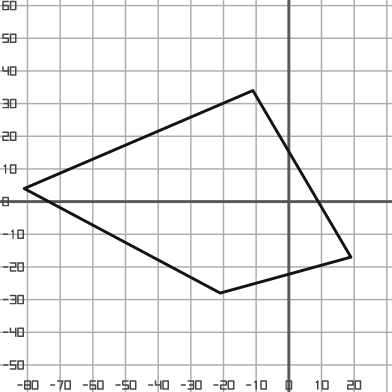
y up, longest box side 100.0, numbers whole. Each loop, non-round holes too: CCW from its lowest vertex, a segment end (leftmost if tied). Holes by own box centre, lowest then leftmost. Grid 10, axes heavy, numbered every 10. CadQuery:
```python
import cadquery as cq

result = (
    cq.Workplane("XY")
    .moveTo(-21.0, -28.0)
    .lineTo(19.0, -17.0)
    .lineTo(-11.0, 34.0)
    .lineTo(-81.0, 4.0)
    .close()
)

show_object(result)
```